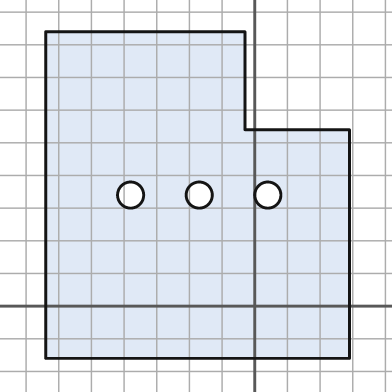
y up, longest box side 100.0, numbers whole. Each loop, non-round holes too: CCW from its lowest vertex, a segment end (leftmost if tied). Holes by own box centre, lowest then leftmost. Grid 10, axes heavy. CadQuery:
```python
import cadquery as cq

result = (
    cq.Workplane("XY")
    .moveTo(-64.0, -16.0)
    .lineTo(29.0, -16.0)
    .lineTo(29.0, 54.0)
    .lineTo(-3.0, 54.0)
    .lineTo(-3.0, 84.0)
    .lineTo(-64.0, 84.0)
    .close()
    .moveTo(-38.0, 34.0)
    .circle(4.0)
    .moveTo(-17.0, 34.0)
    .circle(4.0)
    .moveTo(4.0, 34.0)
    .circle(4.0)
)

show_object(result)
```